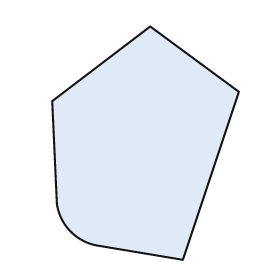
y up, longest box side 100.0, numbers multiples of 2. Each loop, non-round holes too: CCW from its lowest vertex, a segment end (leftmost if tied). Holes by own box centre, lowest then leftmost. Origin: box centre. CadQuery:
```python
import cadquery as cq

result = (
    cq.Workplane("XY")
    .moveTo(16.0, -50.0)
    .lineTo(40.0, 22.0)
    .lineTo(2.0, 50.0)
    .lineTo(-40.0, 18.0)
    .lineTo(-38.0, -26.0)
    .threePointArc((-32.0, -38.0), (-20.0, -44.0))
    .close()
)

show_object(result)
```